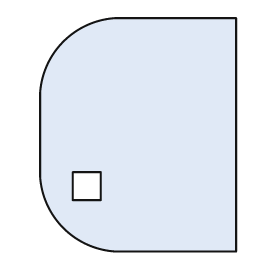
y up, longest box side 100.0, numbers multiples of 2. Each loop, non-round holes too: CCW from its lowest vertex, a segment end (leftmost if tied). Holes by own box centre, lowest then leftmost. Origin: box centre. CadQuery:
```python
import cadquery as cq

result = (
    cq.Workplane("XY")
    .moveTo(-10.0, -50.0)
    .lineTo(42.0, -50.0)
    .lineTo(42.0, 50.0)
    .lineTo(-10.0, 50.0)
    .threePointArc((-32.0, 40.0), (-42.0, 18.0))
    .lineTo(-42.0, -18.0)
    .threePointArc((-32.0, -40.0), (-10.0, -50.0))
    .close()
    .moveTo(-28.0, -28.0)
    .lineTo(-16.0, -28.0)
    .lineTo(-16.0, -16.0)
    .lineTo(-28.0, -16.0)
    .close()
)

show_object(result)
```